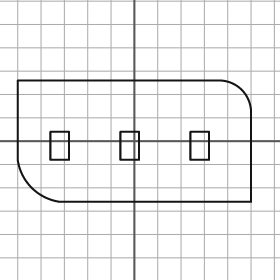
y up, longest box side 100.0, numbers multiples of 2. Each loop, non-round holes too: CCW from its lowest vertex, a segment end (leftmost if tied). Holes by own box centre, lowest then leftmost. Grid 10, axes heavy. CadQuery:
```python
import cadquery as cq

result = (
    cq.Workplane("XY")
    .moveTo(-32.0, -26.0)
    .lineTo(50.0, -26.0)
    .lineTo(50.0, 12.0)
    .threePointArc((46.0, 22.0), (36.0, 26.0))
    .lineTo(-50.0, 26.0)
    .lineTo(-50.0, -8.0)
    .threePointArc((-44.0, -20.0), (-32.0, -26.0))
    .close()
    .moveTo(-36.0, -8.0)
    .lineTo(-28.0, -8.0)
    .lineTo(-28.0, 4.0)
    .lineTo(-36.0, 4.0)
    .close()
    .moveTo(-6.0, -8.0)
    .lineTo(2.0, -8.0)
    .lineTo(2.0, 4.0)
    .lineTo(-6.0, 4.0)
    .close()
    .moveTo(24.0, -8.0)
    .lineTo(32.0, -8.0)
    .lineTo(32.0, 4.0)
    .lineTo(24.0, 4.0)
    .close()
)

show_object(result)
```